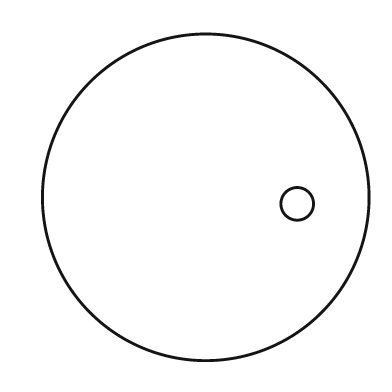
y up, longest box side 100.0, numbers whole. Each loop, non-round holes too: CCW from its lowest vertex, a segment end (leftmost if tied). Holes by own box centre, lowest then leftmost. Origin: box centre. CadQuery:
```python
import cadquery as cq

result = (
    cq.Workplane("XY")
    .moveTo(0.0, 0.0)
    .circle(50.0)
    .moveTo(28.0, -2.0)
    .circle(5.0)
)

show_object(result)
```